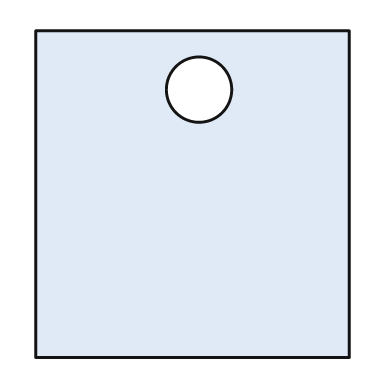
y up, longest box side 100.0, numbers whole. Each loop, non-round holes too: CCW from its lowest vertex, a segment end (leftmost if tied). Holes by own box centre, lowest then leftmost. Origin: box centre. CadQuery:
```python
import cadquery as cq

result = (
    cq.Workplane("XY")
    .moveTo(-48.0, -50.0)
    .lineTo(48.0, -50.0)
    .lineTo(48.0, 50.0)
    .lineTo(-48.0, 50.0)
    .close()
    .moveTo(2.0, 32.0)
    .circle(10.0)
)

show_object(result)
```